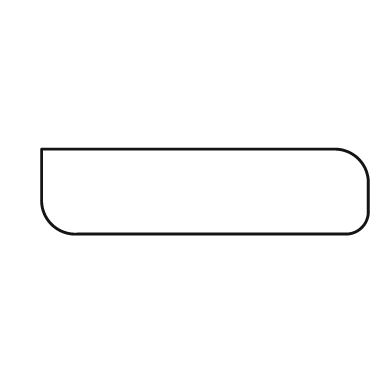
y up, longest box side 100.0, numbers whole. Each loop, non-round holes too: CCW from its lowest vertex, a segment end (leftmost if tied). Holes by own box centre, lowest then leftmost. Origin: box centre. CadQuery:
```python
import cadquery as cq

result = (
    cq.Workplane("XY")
    .moveTo(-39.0, -13.0)
    .lineTo(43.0, -13.0)
    .threePointArc((48.0, -11.0), (50.0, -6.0))
    .lineTo(50.0, 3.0)
    .threePointArc((47.0, 10.0), (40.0, 13.0))
    .lineTo(-50.0, 13.0)
    .lineTo(-50.0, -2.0)
    .threePointArc((-47.0, -10.0), (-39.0, -13.0))
    .close()
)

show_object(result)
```